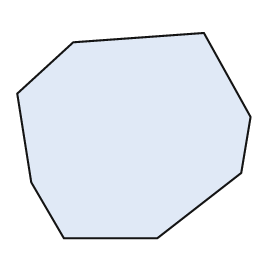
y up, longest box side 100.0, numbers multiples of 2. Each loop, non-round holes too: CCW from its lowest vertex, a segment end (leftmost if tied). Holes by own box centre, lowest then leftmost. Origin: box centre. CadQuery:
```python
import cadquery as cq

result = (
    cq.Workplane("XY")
    .moveTo(-30.0, -44.0)
    .lineTo(10.0, -44.0)
    .lineTo(46.0, -16.0)
    .lineTo(50.0, 8.0)
    .lineTo(30.0, 44.0)
    .lineTo(-26.0, 40.0)
    .lineTo(-50.0, 18.0)
    .lineTo(-44.0, -20.0)
    .close()
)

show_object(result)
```